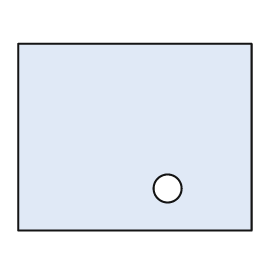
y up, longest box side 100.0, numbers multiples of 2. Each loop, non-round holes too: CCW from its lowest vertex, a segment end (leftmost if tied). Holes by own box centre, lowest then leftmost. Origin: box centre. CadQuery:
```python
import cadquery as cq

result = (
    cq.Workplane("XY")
    .moveTo(-50.0, -40.0)
    .lineTo(50.0, -40.0)
    .lineTo(50.0, 40.0)
    .lineTo(-50.0, 40.0)
    .close()
    .moveTo(14.0, -22.0)
    .circle(6.0)
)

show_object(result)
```